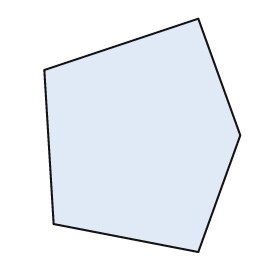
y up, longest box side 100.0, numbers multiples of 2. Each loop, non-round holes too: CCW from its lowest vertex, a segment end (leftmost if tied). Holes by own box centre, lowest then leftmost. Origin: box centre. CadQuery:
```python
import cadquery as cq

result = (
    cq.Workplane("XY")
    .moveTo(24.0, -50.0)
    .lineTo(42.0, 0.0)
    .lineTo(24.0, 50.0)
    .lineTo(-42.0, 28.0)
    .lineTo(-38.0, -38.0)
    .close()
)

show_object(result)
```